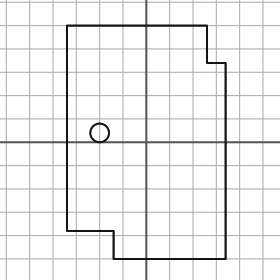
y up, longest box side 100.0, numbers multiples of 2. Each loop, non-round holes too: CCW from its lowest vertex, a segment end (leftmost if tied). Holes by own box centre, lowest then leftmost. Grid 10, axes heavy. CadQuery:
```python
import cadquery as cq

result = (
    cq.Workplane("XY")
    .moveTo(-14.0, -50.0)
    .lineTo(34.0, -50.0)
    .lineTo(34.0, 34.0)
    .lineTo(26.0, 34.0)
    .lineTo(26.0, 50.0)
    .lineTo(-34.0, 50.0)
    .lineTo(-34.0, -38.0)
    .lineTo(-14.0, -38.0)
    .close()
    .moveTo(-20.0, 4.0)
    .circle(4.0)
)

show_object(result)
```